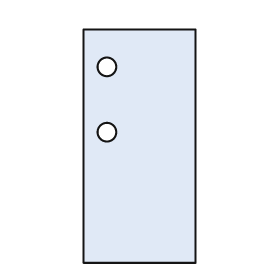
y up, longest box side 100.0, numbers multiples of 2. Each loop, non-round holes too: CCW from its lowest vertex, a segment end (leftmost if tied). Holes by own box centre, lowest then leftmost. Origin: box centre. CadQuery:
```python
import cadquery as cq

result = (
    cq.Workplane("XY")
    .moveTo(-24.0, -50.0)
    .lineTo(24.0, -50.0)
    .lineTo(24.0, 50.0)
    .lineTo(-24.0, 50.0)
    .close()
    .moveTo(-14.0, 6.0)
    .circle(4.0)
    .moveTo(-14.0, 34.0)
    .circle(4.0)
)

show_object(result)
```